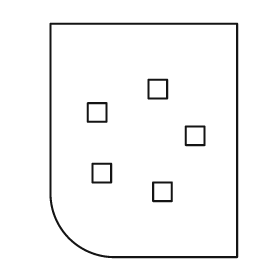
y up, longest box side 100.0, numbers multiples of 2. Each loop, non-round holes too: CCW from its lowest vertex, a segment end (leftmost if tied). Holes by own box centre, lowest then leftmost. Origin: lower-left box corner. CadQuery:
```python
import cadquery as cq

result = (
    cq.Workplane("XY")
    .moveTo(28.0, 0.0)
    .lineTo(80.0, 0.0)
    .lineTo(80.0, 100.0)
    .lineTo(0.0, 100.0)
    .lineTo(0.0, 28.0)
    .threePointArc((8.0, 8.0), (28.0, 0.0))
    .close()
    .moveTo(44.0, 24.0)
    .lineTo(52.0, 24.0)
    .lineTo(52.0, 32.0)
    .lineTo(44.0, 32.0)
    .close()
    .moveTo(18.0, 32.0)
    .lineTo(26.0, 32.0)
    .lineTo(26.0, 40.0)
    .lineTo(18.0, 40.0)
    .close()
    .moveTo(58.0, 48.0)
    .lineTo(66.0, 48.0)
    .lineTo(66.0, 56.0)
    .lineTo(58.0, 56.0)
    .close()
    .moveTo(16.0, 58.0)
    .lineTo(24.0, 58.0)
    .lineTo(24.0, 66.0)
    .lineTo(16.0, 66.0)
    .close()
    .moveTo(42.0, 68.0)
    .lineTo(50.0, 68.0)
    .lineTo(50.0, 76.0)
    .lineTo(42.0, 76.0)
    .close()
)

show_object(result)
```